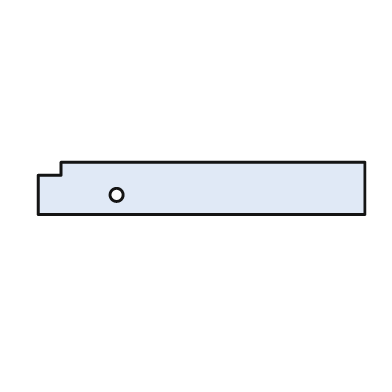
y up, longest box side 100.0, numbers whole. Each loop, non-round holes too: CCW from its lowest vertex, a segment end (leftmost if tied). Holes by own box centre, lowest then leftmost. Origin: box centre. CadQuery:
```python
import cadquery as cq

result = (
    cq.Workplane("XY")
    .moveTo(-50.0, -8.0)
    .lineTo(50.0, -8.0)
    .lineTo(50.0, 8.0)
    .lineTo(-43.0, 8.0)
    .lineTo(-43.0, 4.0)
    .lineTo(-50.0, 4.0)
    .close()
    .moveTo(-26.0, -2.0)
    .circle(2.0)
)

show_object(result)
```